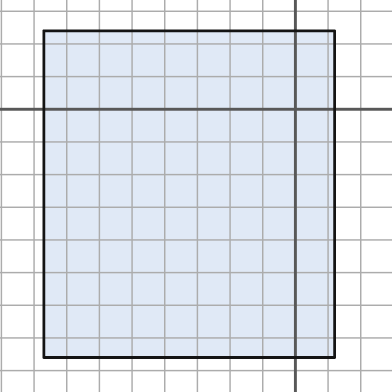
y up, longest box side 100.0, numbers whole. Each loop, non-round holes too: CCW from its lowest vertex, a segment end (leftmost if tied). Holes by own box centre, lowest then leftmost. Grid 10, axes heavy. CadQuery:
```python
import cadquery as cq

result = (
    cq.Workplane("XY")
    .moveTo(-77.0, -76.0)
    .lineTo(12.0, -76.0)
    .lineTo(12.0, 24.0)
    .lineTo(-77.0, 24.0)
    .close()
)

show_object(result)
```